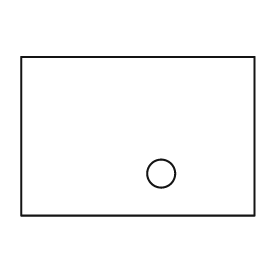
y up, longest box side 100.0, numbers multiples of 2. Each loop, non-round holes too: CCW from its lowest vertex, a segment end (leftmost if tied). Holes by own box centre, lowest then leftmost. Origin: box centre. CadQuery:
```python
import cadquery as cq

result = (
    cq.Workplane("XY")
    .moveTo(-50.0, -34.0)
    .lineTo(50.0, -34.0)
    .lineTo(50.0, 34.0)
    .lineTo(-50.0, 34.0)
    .close()
    .moveTo(10.0, -16.0)
    .circle(6.0)
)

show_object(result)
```